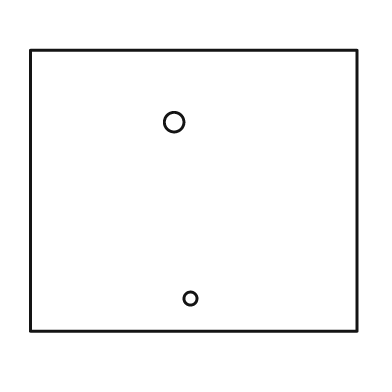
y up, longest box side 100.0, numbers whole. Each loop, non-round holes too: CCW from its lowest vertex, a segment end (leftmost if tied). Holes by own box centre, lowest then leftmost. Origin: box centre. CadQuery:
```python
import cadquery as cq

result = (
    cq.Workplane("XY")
    .moveTo(-50.0, -43.0)
    .lineTo(50.0, -43.0)
    .lineTo(50.0, 43.0)
    .lineTo(-50.0, 43.0)
    .close()
    .moveTo(-1.0, -33.0)
    .circle(2.0)
    .moveTo(-6.0, 21.0)
    .circle(3.0)
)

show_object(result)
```